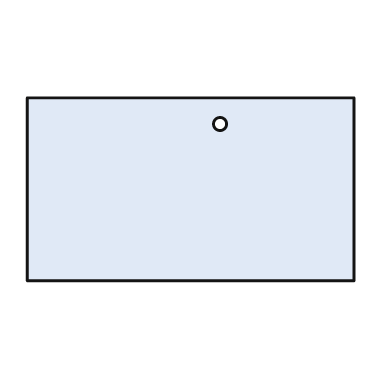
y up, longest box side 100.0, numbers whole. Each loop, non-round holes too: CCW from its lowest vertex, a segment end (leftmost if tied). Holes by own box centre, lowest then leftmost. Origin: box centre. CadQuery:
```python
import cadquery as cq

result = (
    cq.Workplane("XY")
    .moveTo(-50.0, -28.0)
    .lineTo(50.0, -28.0)
    .lineTo(50.0, 28.0)
    .lineTo(-50.0, 28.0)
    .close()
    .moveTo(9.0, 20.0)
    .circle(2.0)
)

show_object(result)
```